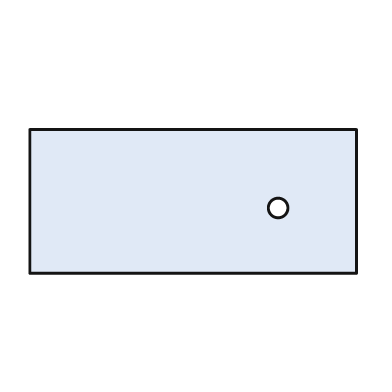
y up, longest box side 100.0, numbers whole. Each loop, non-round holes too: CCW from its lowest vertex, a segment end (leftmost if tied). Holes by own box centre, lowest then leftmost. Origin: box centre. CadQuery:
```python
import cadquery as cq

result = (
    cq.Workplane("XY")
    .moveTo(-50.0, -22.0)
    .lineTo(50.0, -22.0)
    .lineTo(50.0, 22.0)
    .lineTo(-50.0, 22.0)
    .close()
    .moveTo(26.0, -2.0)
    .circle(3.0)
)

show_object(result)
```